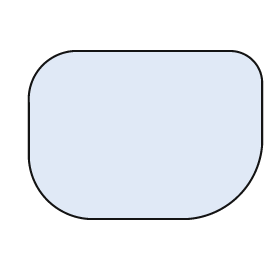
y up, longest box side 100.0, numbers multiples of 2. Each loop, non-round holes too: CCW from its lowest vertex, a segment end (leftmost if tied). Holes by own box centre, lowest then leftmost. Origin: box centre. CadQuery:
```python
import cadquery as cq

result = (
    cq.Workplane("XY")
    .moveTo(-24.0, -36.0)
    .lineTo(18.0, -36.0)
    .threePointArc((40.0, -26.0), (50.0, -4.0))
    .lineTo(50.0, 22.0)
    .threePointArc((46.0, 32.0), (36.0, 36.0))
    .lineTo(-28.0, 36.0)
    .threePointArc((-44.0, 30.0), (-50.0, 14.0))
    .lineTo(-50.0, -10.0)
    .threePointArc((-42.0, -28.0), (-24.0, -36.0))
    .close()
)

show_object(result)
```